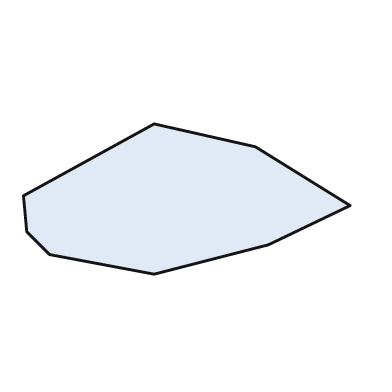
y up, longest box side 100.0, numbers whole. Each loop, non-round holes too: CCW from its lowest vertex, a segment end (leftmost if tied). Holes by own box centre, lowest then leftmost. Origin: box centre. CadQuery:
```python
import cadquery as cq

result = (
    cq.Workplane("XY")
    .moveTo(-10.0, -23.0)
    .lineTo(25.0, -14.0)
    .lineTo(50.0, -2.0)
    .lineTo(21.0, 16.0)
    .lineTo(-10.0, 23.0)
    .lineTo(-50.0, 1.0)
    .lineTo(-49.0, -10.0)
    .lineTo(-42.0, -17.0)
    .close()
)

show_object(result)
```